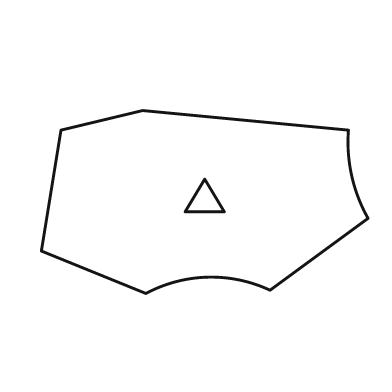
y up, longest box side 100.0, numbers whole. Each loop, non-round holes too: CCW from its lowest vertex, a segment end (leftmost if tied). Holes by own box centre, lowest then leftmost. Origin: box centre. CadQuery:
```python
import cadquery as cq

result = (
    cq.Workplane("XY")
    .moveTo(-18.0, -28.0)
    .threePointArc((1.0, -23.0), (20.0, -27.0))
    .lineTo(50.0, -5.0)
    .threePointArc((45.0, 8.0), (44.0, 22.0))
    .lineTo(-19.0, 28.0)
    .lineTo(-44.0, 22.0)
    .lineTo(-50.0, -15.0)
    .close()
    .moveTo(-6.0, -3.0)
    .lineTo(6.0, -3.0)
    .lineTo(0.0, 7.0)
    .close()
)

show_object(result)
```